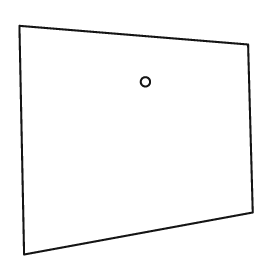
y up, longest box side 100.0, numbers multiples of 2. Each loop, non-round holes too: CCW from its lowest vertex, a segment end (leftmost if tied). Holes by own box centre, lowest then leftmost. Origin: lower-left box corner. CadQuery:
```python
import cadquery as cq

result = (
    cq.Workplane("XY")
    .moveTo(2.0, 0.0)
    .lineTo(100.0, 18.0)
    .lineTo(98.0, 90.0)
    .lineTo(0.0, 98.0)
    .close()
    .moveTo(54.0, 74.0)
    .circle(2.0)
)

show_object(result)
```